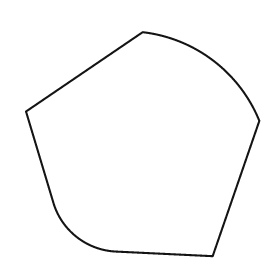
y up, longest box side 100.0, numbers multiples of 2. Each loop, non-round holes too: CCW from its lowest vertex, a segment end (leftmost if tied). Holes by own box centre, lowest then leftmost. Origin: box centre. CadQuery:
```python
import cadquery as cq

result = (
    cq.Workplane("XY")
    .moveTo(30.0, -48.0)
    .lineTo(50.0, 10.0)
    .threePointArc((30.0, 36.0), (0.0, 48.0))
    .lineTo(-50.0, 14.0)
    .lineTo(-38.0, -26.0)
    .threePointArc((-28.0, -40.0), (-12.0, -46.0))
    .close()
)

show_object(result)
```